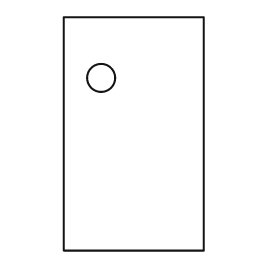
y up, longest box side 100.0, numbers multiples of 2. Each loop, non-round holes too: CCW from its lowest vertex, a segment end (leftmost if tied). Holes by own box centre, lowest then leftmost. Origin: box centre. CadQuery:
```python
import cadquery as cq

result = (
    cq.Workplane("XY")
    .moveTo(-30.0, -50.0)
    .lineTo(30.0, -50.0)
    .lineTo(30.0, 50.0)
    .lineTo(-30.0, 50.0)
    .close()
    .moveTo(-14.0, 24.0)
    .circle(6.0)
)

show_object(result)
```